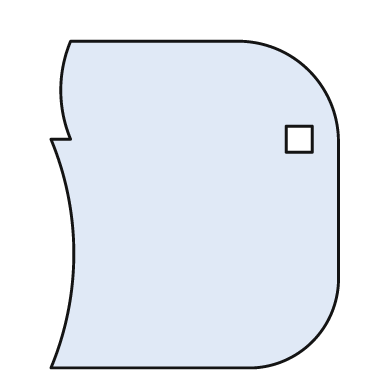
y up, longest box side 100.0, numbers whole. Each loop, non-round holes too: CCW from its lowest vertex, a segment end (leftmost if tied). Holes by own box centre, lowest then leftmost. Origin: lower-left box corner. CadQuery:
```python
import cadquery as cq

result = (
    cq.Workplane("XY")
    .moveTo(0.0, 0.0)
    .lineTo(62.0, 0.0)
    .threePointArc((80.0, 8.0), (88.0, 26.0))
    .lineTo(88.0, 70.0)
    .threePointArc((79.0, 91.0), (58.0, 100.0))
    .lineTo(6.0, 100.0)
    .threePointArc((3.0, 85.0), (6.0, 70.0))
    .lineTo(0.0, 70.0)
    .threePointArc((7.0, 35.0), (0.0, 0.0))
    .close()
    .moveTo(72.0, 66.0)
    .lineTo(80.0, 66.0)
    .lineTo(80.0, 74.0)
    .lineTo(72.0, 74.0)
    .close()
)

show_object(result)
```